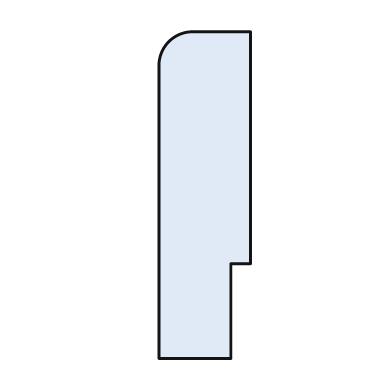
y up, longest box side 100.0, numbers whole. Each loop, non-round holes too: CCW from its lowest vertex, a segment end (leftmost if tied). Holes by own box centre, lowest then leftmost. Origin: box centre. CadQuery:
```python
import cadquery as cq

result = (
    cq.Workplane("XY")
    .moveTo(-14.0, -50.0)
    .lineTo(8.0, -50.0)
    .lineTo(8.0, -21.0)
    .lineTo(14.0, -21.0)
    .lineTo(14.0, 50.0)
    .lineTo(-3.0, 50.0)
    .threePointArc((-11.0, 47.0), (-14.0, 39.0))
    .close()
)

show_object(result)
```